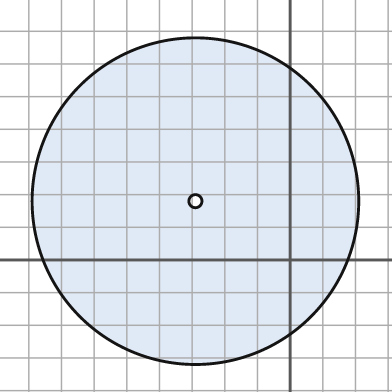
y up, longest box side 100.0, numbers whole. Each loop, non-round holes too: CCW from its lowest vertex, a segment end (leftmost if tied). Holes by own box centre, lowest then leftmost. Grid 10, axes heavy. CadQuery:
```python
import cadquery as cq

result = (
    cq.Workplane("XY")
    .moveTo(-29.0, 18.0)
    .circle(50.0)
    .moveTo(-29.0, 18.0)
    .circle(2.0)
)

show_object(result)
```